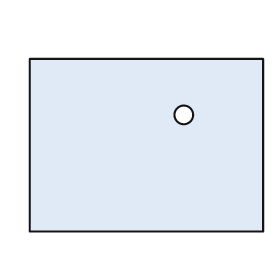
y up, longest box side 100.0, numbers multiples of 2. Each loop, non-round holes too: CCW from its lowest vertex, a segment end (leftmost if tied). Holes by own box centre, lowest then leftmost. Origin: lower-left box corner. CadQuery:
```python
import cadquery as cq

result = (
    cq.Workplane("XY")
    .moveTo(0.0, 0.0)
    .lineTo(100.0, 0.0)
    .lineTo(100.0, 74.0)
    .lineTo(0.0, 74.0)
    .close()
    .moveTo(66.0, 50.0)
    .circle(4.0)
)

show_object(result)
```